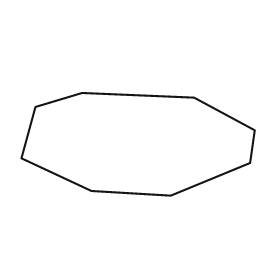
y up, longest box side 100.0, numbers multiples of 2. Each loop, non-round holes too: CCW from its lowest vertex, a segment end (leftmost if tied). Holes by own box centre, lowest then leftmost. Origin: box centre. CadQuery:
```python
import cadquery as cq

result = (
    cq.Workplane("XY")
    .moveTo(14.0, -22.0)
    .lineTo(48.0, -8.0)
    .lineTo(50.0, 6.0)
    .lineTo(24.0, 20.0)
    .lineTo(-24.0, 22.0)
    .lineTo(-44.0, 16.0)
    .lineTo(-50.0, -6.0)
    .lineTo(-20.0, -20.0)
    .close()
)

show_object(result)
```